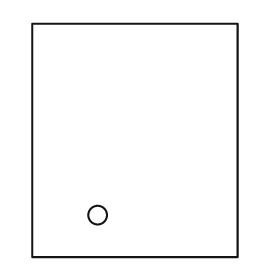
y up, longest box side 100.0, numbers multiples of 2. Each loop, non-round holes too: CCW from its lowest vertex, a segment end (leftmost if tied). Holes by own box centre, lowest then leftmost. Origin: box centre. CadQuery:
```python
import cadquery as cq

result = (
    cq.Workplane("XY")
    .moveTo(-44.0, -50.0)
    .lineTo(44.0, -50.0)
    .lineTo(44.0, 50.0)
    .lineTo(-44.0, 50.0)
    .close()
    .moveTo(-16.0, -32.0)
    .circle(4.0)
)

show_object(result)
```